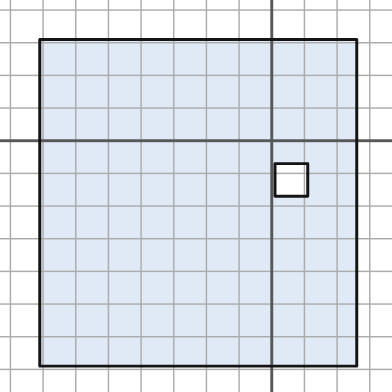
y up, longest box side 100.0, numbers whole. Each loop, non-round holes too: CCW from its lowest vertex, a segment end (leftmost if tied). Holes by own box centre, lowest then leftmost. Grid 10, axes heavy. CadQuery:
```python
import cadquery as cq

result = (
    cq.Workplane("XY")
    .moveTo(-71.0, -69.0)
    .lineTo(26.0, -69.0)
    .lineTo(26.0, 31.0)
    .lineTo(-71.0, 31.0)
    .close()
    .moveTo(1.0, -17.0)
    .lineTo(11.0, -17.0)
    .lineTo(11.0, -7.0)
    .lineTo(1.0, -7.0)
    .close()
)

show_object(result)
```